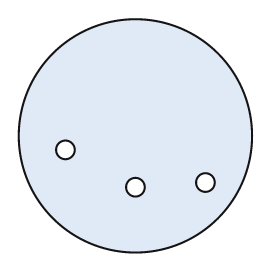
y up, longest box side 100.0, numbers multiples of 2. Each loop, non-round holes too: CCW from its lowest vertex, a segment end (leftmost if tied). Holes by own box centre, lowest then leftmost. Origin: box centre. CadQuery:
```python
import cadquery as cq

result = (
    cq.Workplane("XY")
    .moveTo(0.0, 0.0)
    .circle(50.0)
    .moveTo(0.0, -22.0)
    .circle(4.0)
    .moveTo(30.0, -20.0)
    .circle(4.0)
    .moveTo(-30.0, -6.0)
    .circle(4.0)
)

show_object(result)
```